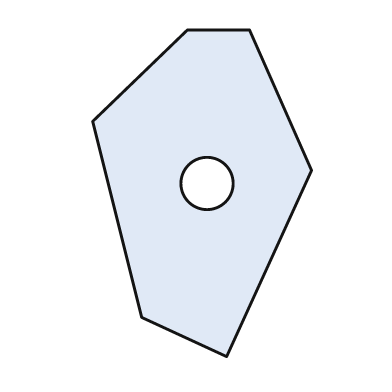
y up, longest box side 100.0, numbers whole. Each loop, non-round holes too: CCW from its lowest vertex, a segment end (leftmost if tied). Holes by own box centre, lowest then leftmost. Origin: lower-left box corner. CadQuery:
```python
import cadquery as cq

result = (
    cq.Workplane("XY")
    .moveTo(41.0, 0.0)
    .lineTo(67.0, 57.0)
    .lineTo(48.0, 100.0)
    .lineTo(29.0, 100.0)
    .lineTo(0.0, 72.0)
    .lineTo(15.0, 12.0)
    .close()
    .moveTo(35.0, 53.0)
    .circle(8.0)
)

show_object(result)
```